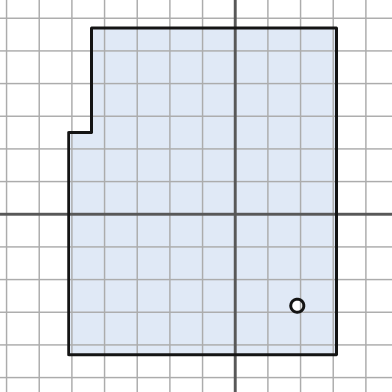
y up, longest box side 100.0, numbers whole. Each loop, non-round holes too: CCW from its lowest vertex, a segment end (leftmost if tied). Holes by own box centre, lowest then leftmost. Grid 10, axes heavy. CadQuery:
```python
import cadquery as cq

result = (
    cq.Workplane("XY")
    .moveTo(-51.0, -43.0)
    .lineTo(31.0, -43.0)
    .lineTo(31.0, 57.0)
    .lineTo(-44.0, 57.0)
    .lineTo(-44.0, 25.0)
    .lineTo(-51.0, 25.0)
    .close()
    .moveTo(19.0, -28.0)
    .circle(2.0)
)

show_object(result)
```